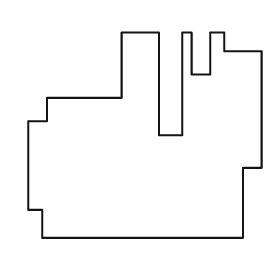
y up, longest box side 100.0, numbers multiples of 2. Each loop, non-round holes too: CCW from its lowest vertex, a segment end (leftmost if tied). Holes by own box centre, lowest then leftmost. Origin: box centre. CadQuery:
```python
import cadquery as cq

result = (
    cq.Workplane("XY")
    .moveTo(-44.0, -44.0)
    .lineTo(42.0, -44.0)
    .lineTo(42.0, -14.0)
    .lineTo(50.0, -14.0)
    .lineTo(50.0, 36.0)
    .lineTo(34.0, 36.0)
    .lineTo(34.0, 44.0)
    .lineTo(28.0, 44.0)
    .lineTo(28.0, 26.0)
    .lineTo(20.0, 26.0)
    .lineTo(20.0, 44.0)
    .lineTo(16.0, 44.0)
    .lineTo(16.0, 0.0)
    .lineTo(6.0, 0.0)
    .lineTo(6.0, 44.0)
    .lineTo(-10.0, 44.0)
    .lineTo(-10.0, 16.0)
    .lineTo(-42.0, 16.0)
    .lineTo(-42.0, 6.0)
    .lineTo(-50.0, 6.0)
    .lineTo(-50.0, -32.0)
    .lineTo(-44.0, -32.0)
    .close()
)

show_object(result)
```